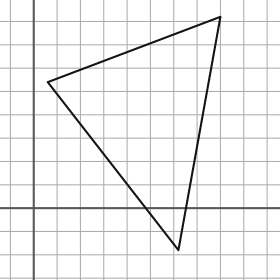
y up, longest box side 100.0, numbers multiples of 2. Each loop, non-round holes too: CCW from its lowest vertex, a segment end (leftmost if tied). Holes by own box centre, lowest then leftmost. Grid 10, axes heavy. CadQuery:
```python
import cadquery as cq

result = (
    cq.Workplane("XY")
    .moveTo(62.0, -18.0)
    .lineTo(80.0, 82.0)
    .lineTo(6.0, 54.0)
    .close()
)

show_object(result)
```